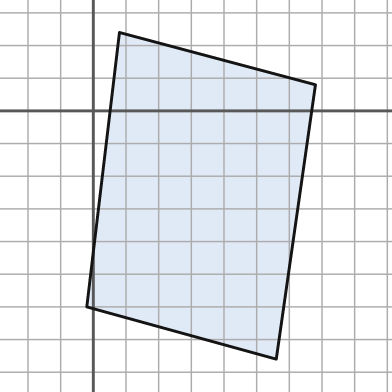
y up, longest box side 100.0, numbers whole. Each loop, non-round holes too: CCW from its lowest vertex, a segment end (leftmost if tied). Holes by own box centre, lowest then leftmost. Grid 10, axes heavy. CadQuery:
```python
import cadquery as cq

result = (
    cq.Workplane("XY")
    .moveTo(56.0, -76.0)
    .lineTo(68.0, 8.0)
    .lineTo(8.0, 24.0)
    .lineTo(-2.0, -60.0)
    .close()
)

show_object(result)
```